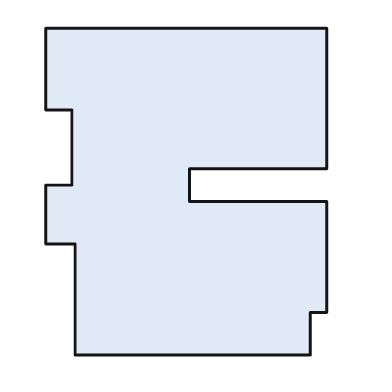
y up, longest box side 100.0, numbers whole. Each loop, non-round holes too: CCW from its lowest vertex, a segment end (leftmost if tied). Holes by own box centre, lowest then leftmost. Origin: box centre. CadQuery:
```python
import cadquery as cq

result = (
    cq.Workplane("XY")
    .moveTo(-34.0, -50.0)
    .lineTo(38.0, -50.0)
    .lineTo(38.0, -37.0)
    .lineTo(43.0, -37.0)
    .lineTo(43.0, -3.0)
    .lineTo(1.0, -3.0)
    .lineTo(1.0, 7.0)
    .lineTo(43.0, 7.0)
    .lineTo(43.0, 50.0)
    .lineTo(-43.0, 50.0)
    .lineTo(-43.0, 25.0)
    .lineTo(-35.0, 25.0)
    .lineTo(-35.0, 2.0)
    .lineTo(-43.0, 2.0)
    .lineTo(-43.0, -16.0)
    .lineTo(-34.0, -16.0)
    .close()
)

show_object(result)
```